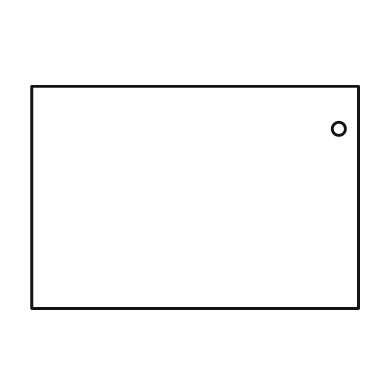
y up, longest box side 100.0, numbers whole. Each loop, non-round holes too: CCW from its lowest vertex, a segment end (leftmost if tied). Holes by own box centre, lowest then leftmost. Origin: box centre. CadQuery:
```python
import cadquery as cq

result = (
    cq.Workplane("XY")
    .moveTo(-50.0, -34.0)
    .lineTo(50.0, -34.0)
    .lineTo(50.0, 34.0)
    .lineTo(-50.0, 34.0)
    .close()
    .moveTo(44.0, 21.0)
    .circle(2.0)
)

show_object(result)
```